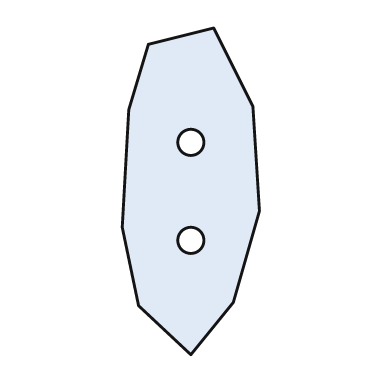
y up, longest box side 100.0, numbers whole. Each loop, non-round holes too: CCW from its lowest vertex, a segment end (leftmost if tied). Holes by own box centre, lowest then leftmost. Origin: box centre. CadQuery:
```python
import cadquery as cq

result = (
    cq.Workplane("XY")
    .moveTo(0.0, -50.0)
    .lineTo(13.0, -34.0)
    .lineTo(21.0, -6.0)
    .lineTo(19.0, 26.0)
    .lineTo(7.0, 50.0)
    .lineTo(-13.0, 45.0)
    .lineTo(-19.0, 25.0)
    .lineTo(-21.0, -11.0)
    .lineTo(-16.0, -35.0)
    .close()
    .moveTo(0.0, -15.0)
    .circle(4.0)
    .moveTo(0.0, 15.0)
    .circle(4.0)
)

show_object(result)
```